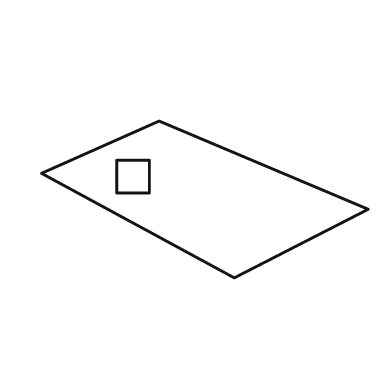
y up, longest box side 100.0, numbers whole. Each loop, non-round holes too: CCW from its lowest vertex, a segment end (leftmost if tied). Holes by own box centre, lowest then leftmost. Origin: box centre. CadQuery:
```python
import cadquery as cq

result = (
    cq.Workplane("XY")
    .moveTo(9.0, -24.0)
    .lineTo(50.0, -3.0)
    .lineTo(-14.0, 24.0)
    .lineTo(-50.0, 8.0)
    .close()
    .moveTo(-27.0, 2.0)
    .lineTo(-17.0, 2.0)
    .lineTo(-17.0, 12.0)
    .lineTo(-27.0, 12.0)
    .close()
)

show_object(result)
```